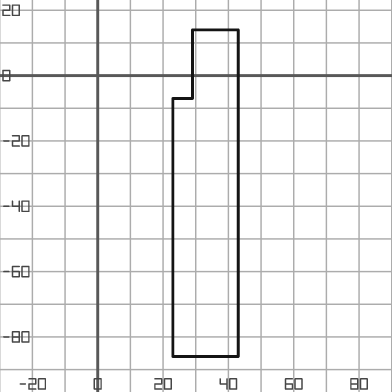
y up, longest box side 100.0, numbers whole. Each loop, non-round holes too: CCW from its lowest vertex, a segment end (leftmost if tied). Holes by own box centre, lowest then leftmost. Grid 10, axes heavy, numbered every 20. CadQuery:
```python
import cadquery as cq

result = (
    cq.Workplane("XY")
    .moveTo(23.0, -86.0)
    .lineTo(43.0, -86.0)
    .lineTo(43.0, 14.0)
    .lineTo(29.0, 14.0)
    .lineTo(29.0, -7.0)
    .lineTo(23.0, -7.0)
    .close()
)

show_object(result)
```